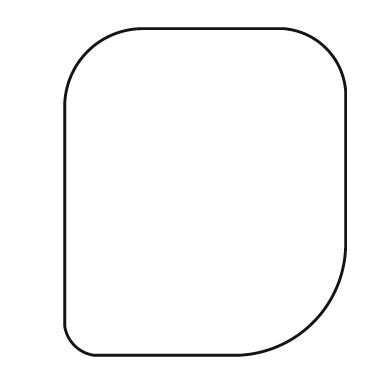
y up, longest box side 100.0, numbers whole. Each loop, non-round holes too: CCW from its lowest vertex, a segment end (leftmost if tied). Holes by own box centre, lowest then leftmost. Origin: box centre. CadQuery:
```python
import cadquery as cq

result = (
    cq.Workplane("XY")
    .moveTo(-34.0, -50.0)
    .lineTo(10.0, -50.0)
    .threePointArc((33.0, -40.0), (43.0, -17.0))
    .lineTo(43.0, 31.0)
    .threePointArc((37.0, 44.0), (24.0, 50.0))
    .lineTo(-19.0, 50.0)
    .threePointArc((-36.0, 43.0), (-43.0, 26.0))
    .lineTo(-43.0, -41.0)
    .threePointArc((-40.0, -47.0), (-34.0, -50.0))
    .close()
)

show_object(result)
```